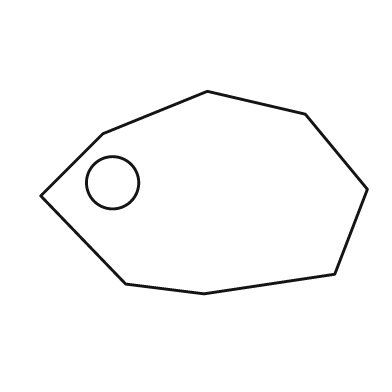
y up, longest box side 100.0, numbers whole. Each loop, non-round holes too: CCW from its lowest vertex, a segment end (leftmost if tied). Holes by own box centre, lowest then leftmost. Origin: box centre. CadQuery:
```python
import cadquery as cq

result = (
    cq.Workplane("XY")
    .moveTo(0.0, -31.0)
    .lineTo(40.0, -25.0)
    .lineTo(50.0, 1.0)
    .lineTo(31.0, 24.0)
    .lineTo(1.0, 31.0)
    .lineTo(-31.0, 18.0)
    .lineTo(-50.0, -1.0)
    .lineTo(-24.0, -28.0)
    .close()
    .moveTo(-28.0, 3.0)
    .circle(8.0)
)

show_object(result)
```